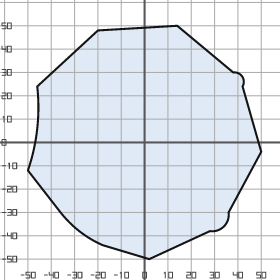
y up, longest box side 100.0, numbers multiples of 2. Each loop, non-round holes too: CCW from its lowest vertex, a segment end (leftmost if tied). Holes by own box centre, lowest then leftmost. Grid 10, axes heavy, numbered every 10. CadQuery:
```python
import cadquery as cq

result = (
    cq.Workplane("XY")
    .moveTo(2.0, -50.0)
    .lineTo(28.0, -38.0)
    .threePointArc((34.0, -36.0), (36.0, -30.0))
    .lineTo(50.0, -4.0)
    .lineTo(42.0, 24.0)
    .threePointArc((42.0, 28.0), (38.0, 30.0))
    .lineTo(14.0, 50.0)
    .lineTo(-20.0, 48.0)
    .lineTo(-46.0, 24.0)
    .threePointArc((-46.0, 6.0), (-50.0, -12.0))
    .lineTo(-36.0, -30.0)
    .threePointArc((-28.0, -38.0), (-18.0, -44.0))
    .close()
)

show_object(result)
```